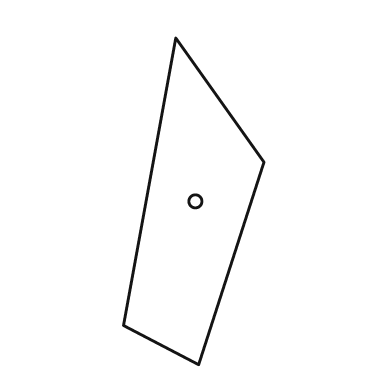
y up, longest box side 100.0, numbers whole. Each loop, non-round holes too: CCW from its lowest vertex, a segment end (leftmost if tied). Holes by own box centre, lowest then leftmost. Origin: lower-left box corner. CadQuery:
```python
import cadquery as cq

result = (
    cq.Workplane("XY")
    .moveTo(23.0, 0.0)
    .lineTo(43.0, 62.0)
    .lineTo(16.0, 100.0)
    .lineTo(0.0, 12.0)
    .close()
    .moveTo(22.0, 50.0)
    .circle(2.0)
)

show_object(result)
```